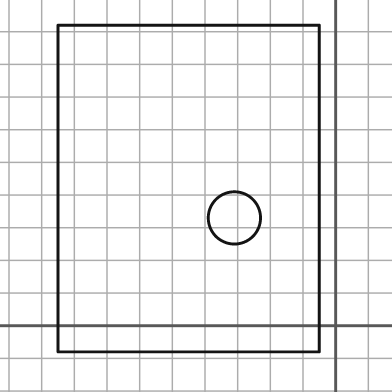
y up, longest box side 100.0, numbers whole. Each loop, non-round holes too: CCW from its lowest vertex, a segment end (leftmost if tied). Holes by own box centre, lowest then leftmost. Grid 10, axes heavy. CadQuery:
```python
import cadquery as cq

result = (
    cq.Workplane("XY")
    .moveTo(-85.0, -8.0)
    .lineTo(-5.0, -8.0)
    .lineTo(-5.0, 92.0)
    .lineTo(-85.0, 92.0)
    .close()
    .moveTo(-31.0, 33.0)
    .circle(8.0)
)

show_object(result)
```